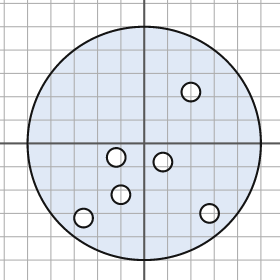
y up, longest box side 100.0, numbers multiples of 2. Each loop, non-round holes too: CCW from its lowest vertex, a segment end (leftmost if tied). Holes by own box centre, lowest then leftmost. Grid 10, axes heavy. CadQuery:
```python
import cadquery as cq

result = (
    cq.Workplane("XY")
    .moveTo(0.0, 0.0)
    .circle(50.0)
    .moveTo(-26.0, -32.0)
    .circle(4.0)
    .moveTo(28.0, -30.0)
    .circle(4.0)
    .moveTo(-10.0, -22.0)
    .circle(4.0)
    .moveTo(8.0, -8.0)
    .circle(4.0)
    .moveTo(-12.0, -6.0)
    .circle(4.0)
    .moveTo(20.0, 22.0)
    .circle(4.0)
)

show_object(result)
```